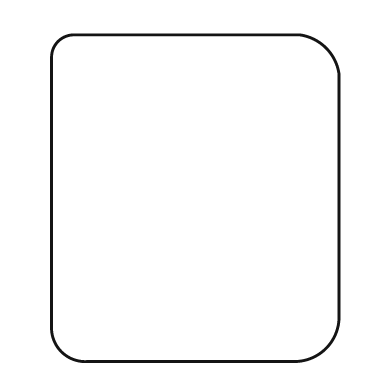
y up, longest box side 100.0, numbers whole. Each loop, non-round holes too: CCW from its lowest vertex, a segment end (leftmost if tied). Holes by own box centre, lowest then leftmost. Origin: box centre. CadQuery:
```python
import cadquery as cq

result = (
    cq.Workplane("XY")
    .moveTo(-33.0, -50.0)
    .lineTo(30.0, -50.0)
    .threePointArc((40.0, -46.0), (44.0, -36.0))
    .lineTo(44.0, 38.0)
    .threePointArc((40.0, 46.0), (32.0, 50.0))
    .lineTo(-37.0, 50.0)
    .threePointArc((-42.0, 48.0), (-44.0, 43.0))
    .lineTo(-44.0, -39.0)
    .threePointArc((-41.0, -47.0), (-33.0, -50.0))
    .close()
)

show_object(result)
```